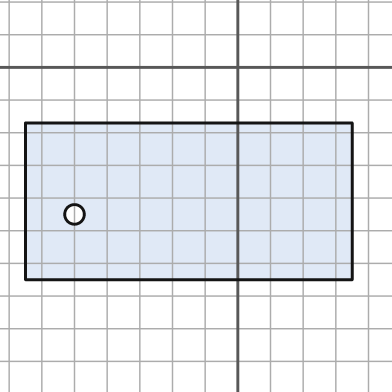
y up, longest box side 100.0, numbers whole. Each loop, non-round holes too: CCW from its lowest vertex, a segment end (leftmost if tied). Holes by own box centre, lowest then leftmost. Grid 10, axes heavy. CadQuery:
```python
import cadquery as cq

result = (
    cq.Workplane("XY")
    .moveTo(-65.0, -65.0)
    .lineTo(35.0, -65.0)
    .lineTo(35.0, -17.0)
    .lineTo(-65.0, -17.0)
    .close()
    .moveTo(-50.0, -45.0)
    .circle(3.0)
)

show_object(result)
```